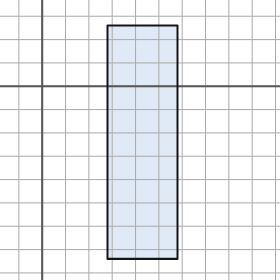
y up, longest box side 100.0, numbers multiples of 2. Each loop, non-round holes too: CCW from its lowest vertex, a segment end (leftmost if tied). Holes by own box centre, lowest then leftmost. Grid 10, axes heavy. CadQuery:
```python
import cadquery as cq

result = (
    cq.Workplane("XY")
    .moveTo(28.0, -74.0)
    .lineTo(58.0, -74.0)
    .lineTo(58.0, 26.0)
    .lineTo(28.0, 26.0)
    .close()
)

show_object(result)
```